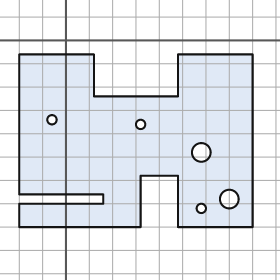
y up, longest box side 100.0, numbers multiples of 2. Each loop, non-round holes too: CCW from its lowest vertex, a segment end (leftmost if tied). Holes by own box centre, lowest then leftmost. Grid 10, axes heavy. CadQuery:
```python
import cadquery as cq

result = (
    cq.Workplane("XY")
    .moveTo(-20.0, -80.0)
    .lineTo(32.0, -80.0)
    .lineTo(32.0, -58.0)
    .lineTo(48.0, -58.0)
    .lineTo(48.0, -80.0)
    .lineTo(80.0, -80.0)
    .lineTo(80.0, -6.0)
    .lineTo(48.0, -6.0)
    .lineTo(48.0, -24.0)
    .lineTo(12.0, -24.0)
    .lineTo(12.0, -6.0)
    .lineTo(-20.0, -6.0)
    .lineTo(-20.0, -66.0)
    .lineTo(16.0, -66.0)
    .lineTo(16.0, -70.0)
    .lineTo(-20.0, -70.0)
    .close()
    .moveTo(58.0, -72.0)
    .circle(2.0)
    .moveTo(70.0, -68.0)
    .circle(4.0)
    .moveTo(58.0, -48.0)
    .circle(4.0)
    .moveTo(32.0, -36.0)
    .circle(2.0)
    .moveTo(-6.0, -34.0)
    .circle(2.0)
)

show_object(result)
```